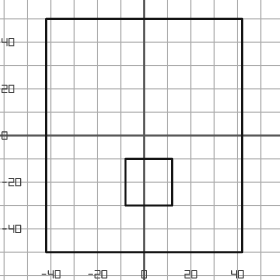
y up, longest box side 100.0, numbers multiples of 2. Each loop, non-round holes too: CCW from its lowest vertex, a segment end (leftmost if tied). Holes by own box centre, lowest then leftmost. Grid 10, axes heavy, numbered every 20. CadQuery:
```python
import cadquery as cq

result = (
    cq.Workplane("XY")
    .moveTo(-42.0, -50.0)
    .lineTo(42.0, -50.0)
    .lineTo(42.0, 50.0)
    .lineTo(-42.0, 50.0)
    .close()
    .moveTo(-8.0, -30.0)
    .lineTo(12.0, -30.0)
    .lineTo(12.0, -10.0)
    .lineTo(-8.0, -10.0)
    .close()
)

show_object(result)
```